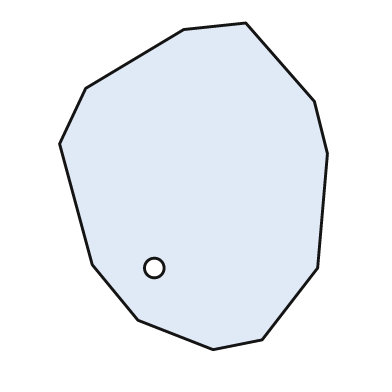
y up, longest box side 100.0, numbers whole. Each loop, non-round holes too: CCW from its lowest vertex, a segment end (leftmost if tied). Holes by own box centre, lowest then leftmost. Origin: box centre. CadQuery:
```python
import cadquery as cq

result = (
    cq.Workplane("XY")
    .moveTo(6.0, -50.0)
    .lineTo(21.0, -47.0)
    .lineTo(38.0, -25.0)
    .lineTo(41.0, 10.0)
    .lineTo(37.0, 26.0)
    .lineTo(16.0, 50.0)
    .lineTo(-3.0, 48.0)
    .lineTo(-33.0, 30.0)
    .lineTo(-41.0, 13.0)
    .lineTo(-31.0, -24.0)
    .lineTo(-17.0, -41.0)
    .close()
    .moveTo(-12.0, -25.0)
    .circle(3.0)
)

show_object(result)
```